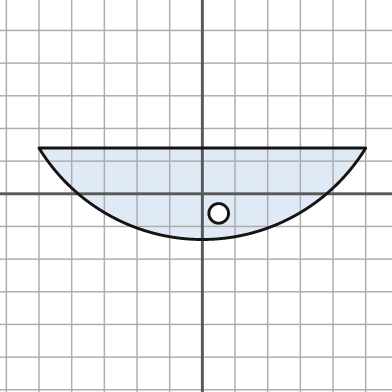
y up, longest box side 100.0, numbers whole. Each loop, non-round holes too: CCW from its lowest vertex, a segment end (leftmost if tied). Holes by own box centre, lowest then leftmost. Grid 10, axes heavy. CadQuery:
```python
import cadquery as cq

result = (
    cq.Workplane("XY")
    .moveTo(-50.0, 14.0)
    .threePointArc((0.0, -14.0), (50.0, 14.0))
    .close()
    .moveTo(5.0, -6.0)
    .circle(3.0)
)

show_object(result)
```